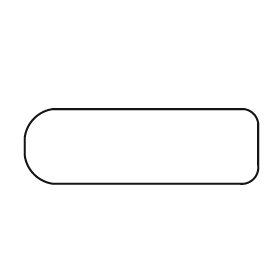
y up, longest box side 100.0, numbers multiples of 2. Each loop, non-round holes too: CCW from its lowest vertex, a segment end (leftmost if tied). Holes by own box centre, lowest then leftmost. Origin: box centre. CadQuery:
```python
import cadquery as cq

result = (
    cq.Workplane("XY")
    .moveTo(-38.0, -16.0)
    .lineTo(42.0, -16.0)
    .threePointArc((48.0, -14.0), (50.0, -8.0))
    .lineTo(50.0, 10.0)
    .threePointArc((48.0, 14.0), (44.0, 16.0))
    .lineTo(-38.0, 16.0)
    .threePointArc((-46.0, 12.0), (-50.0, 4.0))
    .lineTo(-50.0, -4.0)
    .threePointArc((-46.0, -12.0), (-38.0, -16.0))
    .close()
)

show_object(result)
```